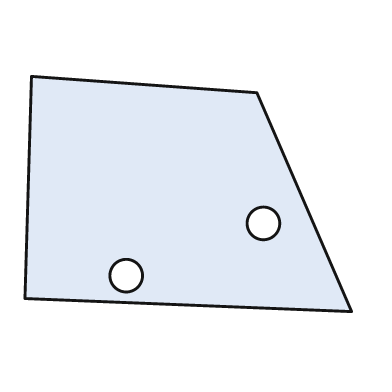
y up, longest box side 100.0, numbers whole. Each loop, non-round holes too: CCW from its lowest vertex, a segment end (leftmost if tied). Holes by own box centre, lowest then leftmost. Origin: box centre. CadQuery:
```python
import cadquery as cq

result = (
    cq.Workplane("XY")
    .moveTo(50.0, -36.0)
    .lineTo(21.0, 31.0)
    .lineTo(-48.0, 36.0)
    .lineTo(-50.0, -32.0)
    .close()
    .moveTo(-19.0, -25.0)
    .circle(5.0)
    .moveTo(23.0, -9.0)
    .circle(5.0)
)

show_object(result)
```